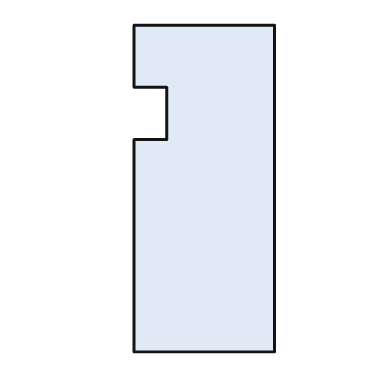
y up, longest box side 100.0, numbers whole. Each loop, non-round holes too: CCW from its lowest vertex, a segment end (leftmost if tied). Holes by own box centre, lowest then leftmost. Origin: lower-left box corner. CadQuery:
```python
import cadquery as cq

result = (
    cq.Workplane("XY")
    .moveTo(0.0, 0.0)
    .lineTo(43.0, 0.0)
    .lineTo(43.0, 100.0)
    .lineTo(0.0, 100.0)
    .lineTo(0.0, 81.0)
    .lineTo(10.0, 81.0)
    .lineTo(10.0, 65.0)
    .lineTo(0.0, 65.0)
    .close()
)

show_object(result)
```